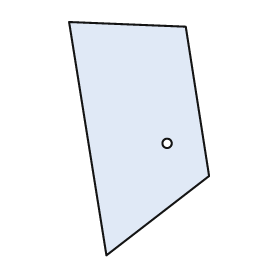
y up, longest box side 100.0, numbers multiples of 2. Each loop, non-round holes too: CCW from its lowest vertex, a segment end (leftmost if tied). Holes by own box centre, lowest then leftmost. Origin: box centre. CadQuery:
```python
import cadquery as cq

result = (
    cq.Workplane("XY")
    .moveTo(-14.0, -50.0)
    .lineTo(30.0, -16.0)
    .lineTo(20.0, 48.0)
    .lineTo(-30.0, 50.0)
    .close()
    .moveTo(12.0, -2.0)
    .circle(2.0)
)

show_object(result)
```